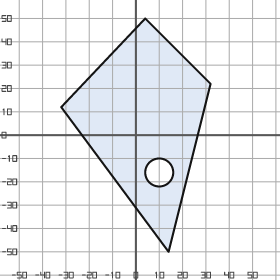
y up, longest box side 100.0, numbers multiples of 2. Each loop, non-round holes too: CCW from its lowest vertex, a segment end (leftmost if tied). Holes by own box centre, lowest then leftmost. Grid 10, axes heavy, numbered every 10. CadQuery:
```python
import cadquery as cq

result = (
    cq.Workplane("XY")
    .moveTo(14.0, -50.0)
    .lineTo(32.0, 22.0)
    .lineTo(4.0, 50.0)
    .lineTo(-32.0, 12.0)
    .close()
    .moveTo(10.0, -16.0)
    .circle(6.0)
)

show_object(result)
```